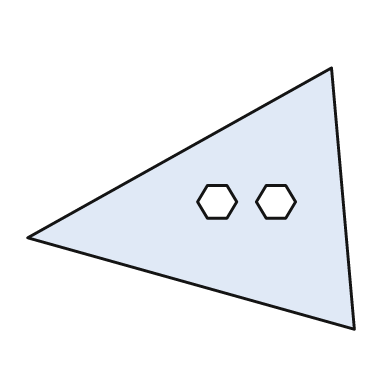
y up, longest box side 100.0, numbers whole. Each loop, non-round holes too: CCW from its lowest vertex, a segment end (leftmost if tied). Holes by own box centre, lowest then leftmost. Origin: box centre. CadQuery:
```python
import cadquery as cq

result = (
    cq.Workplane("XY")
    .moveTo(50.0, -40.0)
    .lineTo(43.0, 40.0)
    .lineTo(-50.0, -12.0)
    .close()
    .moveTo(5.0, -6.0)
    .lineTo(11.0, -6.0)
    .lineTo(14.0, -1.0)
    .lineTo(11.0, 4.0)
    .lineTo(5.0, 4.0)
    .lineTo(2.0, -1.0)
    .close()
    .moveTo(23.0, -6.0)
    .lineTo(29.0, -6.0)
    .lineTo(32.0, -1.0)
    .lineTo(29.0, 4.0)
    .lineTo(23.0, 4.0)
    .lineTo(20.0, -1.0)
    .close()
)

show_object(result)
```